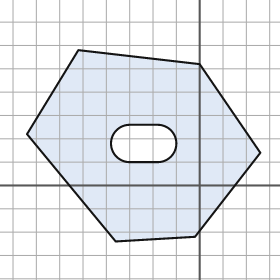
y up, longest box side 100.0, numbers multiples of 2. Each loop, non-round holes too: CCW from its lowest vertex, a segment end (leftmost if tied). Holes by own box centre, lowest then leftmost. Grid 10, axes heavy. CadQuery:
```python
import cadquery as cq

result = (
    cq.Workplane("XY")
    .moveTo(-36.0, -24.0)
    .lineTo(-2.0, -22.0)
    .lineTo(26.0, 14.0)
    .lineTo(0.0, 52.0)
    .lineTo(-52.0, 58.0)
    .lineTo(-74.0, 22.0)
    .close()
    .moveTo(-30.0, 10.0)
    .lineTo(-18.0, 10.0)
    .threePointArc((-10.0, 18.0), (-18.0, 26.0))
    .lineTo(-30.0, 26.0)
    .threePointArc((-38.0, 18.0), (-30.0, 10.0))
    .close()
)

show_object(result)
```